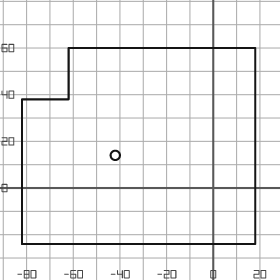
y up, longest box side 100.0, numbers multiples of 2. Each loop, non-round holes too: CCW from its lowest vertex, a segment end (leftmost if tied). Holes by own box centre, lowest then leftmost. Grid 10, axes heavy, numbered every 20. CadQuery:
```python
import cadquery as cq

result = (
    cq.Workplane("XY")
    .moveTo(-82.0, -24.0)
    .lineTo(18.0, -24.0)
    .lineTo(18.0, 60.0)
    .lineTo(-62.0, 60.0)
    .lineTo(-62.0, 38.0)
    .lineTo(-82.0, 38.0)
    .close()
    .moveTo(-42.0, 14.0)
    .circle(2.0)
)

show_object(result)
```